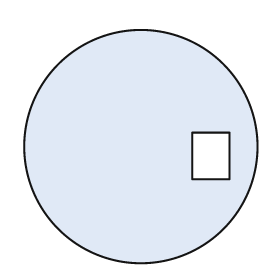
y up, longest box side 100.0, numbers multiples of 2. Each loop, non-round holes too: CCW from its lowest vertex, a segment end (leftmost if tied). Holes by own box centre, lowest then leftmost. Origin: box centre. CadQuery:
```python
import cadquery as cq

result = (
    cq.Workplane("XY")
    .moveTo(0.0, 0.0)
    .circle(50.0)
    .moveTo(22.0, -14.0)
    .lineTo(38.0, -14.0)
    .lineTo(38.0, 6.0)
    .lineTo(22.0, 6.0)
    .close()
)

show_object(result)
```